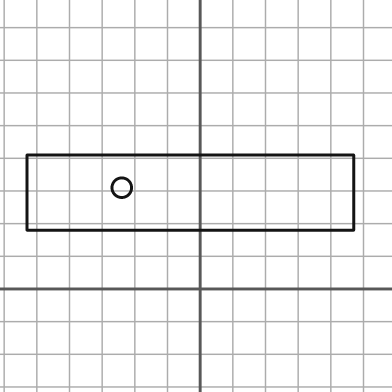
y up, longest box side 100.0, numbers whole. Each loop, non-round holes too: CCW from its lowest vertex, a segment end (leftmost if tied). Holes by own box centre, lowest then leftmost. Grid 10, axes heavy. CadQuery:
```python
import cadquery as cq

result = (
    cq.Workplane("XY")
    .moveTo(-53.0, 18.0)
    .lineTo(47.0, 18.0)
    .lineTo(47.0, 41.0)
    .lineTo(-53.0, 41.0)
    .close()
    .moveTo(-24.0, 31.0)
    .circle(3.0)
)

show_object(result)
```